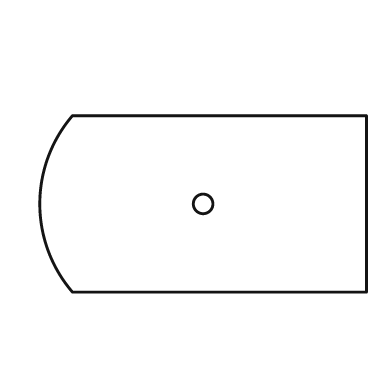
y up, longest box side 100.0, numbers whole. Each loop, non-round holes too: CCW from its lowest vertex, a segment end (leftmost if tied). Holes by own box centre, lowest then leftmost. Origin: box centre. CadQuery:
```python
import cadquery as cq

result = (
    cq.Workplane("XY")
    .moveTo(-40.0, -27.0)
    .lineTo(50.0, -27.0)
    .lineTo(50.0, 27.0)
    .lineTo(-40.0, 27.0)
    .threePointArc((-50.0, 0.0), (-40.0, -27.0))
    .close()
    .moveTo(0.0, 0.0)
    .circle(3.0)
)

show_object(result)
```